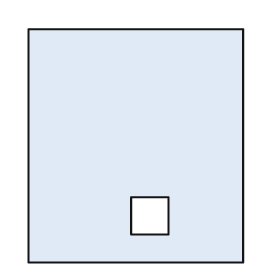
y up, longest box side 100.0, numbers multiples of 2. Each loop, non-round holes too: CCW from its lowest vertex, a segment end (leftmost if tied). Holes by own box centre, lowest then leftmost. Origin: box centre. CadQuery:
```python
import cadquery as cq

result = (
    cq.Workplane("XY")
    .moveTo(-46.0, -50.0)
    .lineTo(46.0, -50.0)
    .lineTo(46.0, 50.0)
    .lineTo(-46.0, 50.0)
    .close()
    .moveTo(-2.0, -38.0)
    .lineTo(14.0, -38.0)
    .lineTo(14.0, -22.0)
    .lineTo(-2.0, -22.0)
    .close()
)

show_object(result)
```